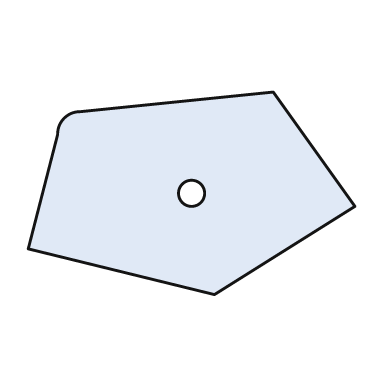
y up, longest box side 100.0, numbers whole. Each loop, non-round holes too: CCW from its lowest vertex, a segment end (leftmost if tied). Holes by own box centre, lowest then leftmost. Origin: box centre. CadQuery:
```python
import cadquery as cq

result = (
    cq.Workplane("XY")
    .moveTo(7.0, -31.0)
    .lineTo(50.0, -4.0)
    .lineTo(25.0, 31.0)
    .lineTo(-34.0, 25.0)
    .threePointArc((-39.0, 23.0), (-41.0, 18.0))
    .lineTo(-50.0, -17.0)
    .close()
    .moveTo(0.0, 0.0)
    .circle(4.0)
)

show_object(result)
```